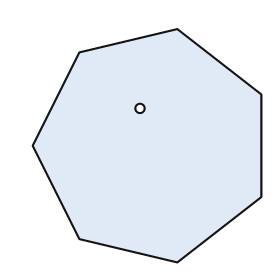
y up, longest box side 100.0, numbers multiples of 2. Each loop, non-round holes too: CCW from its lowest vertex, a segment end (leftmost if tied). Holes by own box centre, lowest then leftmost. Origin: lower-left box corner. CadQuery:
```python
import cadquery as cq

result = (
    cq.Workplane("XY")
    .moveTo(62.0, 0.0)
    .lineTo(98.0, 28.0)
    .lineTo(98.0, 72.0)
    .lineTo(62.0, 100.0)
    .lineTo(20.0, 90.0)
    .lineTo(0.0, 50.0)
    .lineTo(20.0, 10.0)
    .close()
    .moveTo(46.0, 66.0)
    .circle(2.0)
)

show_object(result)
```